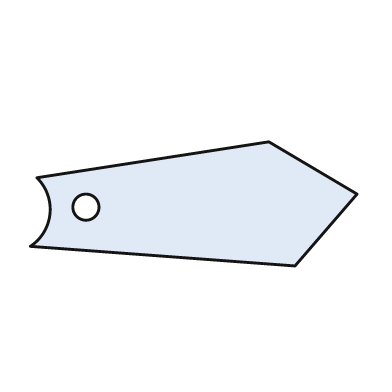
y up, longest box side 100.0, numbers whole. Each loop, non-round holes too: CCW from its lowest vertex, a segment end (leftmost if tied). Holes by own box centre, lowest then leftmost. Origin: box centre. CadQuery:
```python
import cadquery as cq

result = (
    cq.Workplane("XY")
    .moveTo(31.0, -19.0)
    .lineTo(50.0, 3.0)
    .lineTo(23.0, 19.0)
    .lineTo(-48.0, 8.0)
    .threePointArc((-44.0, -3.0), (-50.0, -13.0))
    .close()
    .moveTo(-33.0, -1.0)
    .circle(4.0)
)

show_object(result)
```